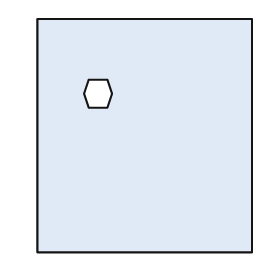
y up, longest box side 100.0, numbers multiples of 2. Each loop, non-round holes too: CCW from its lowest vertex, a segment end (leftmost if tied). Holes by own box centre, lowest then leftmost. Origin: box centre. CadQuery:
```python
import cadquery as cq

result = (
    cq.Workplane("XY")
    .moveTo(-46.0, -50.0)
    .lineTo(46.0, -50.0)
    .lineTo(46.0, 50.0)
    .lineTo(-46.0, 50.0)
    .close()
    .moveTo(-24.0, 12.0)
    .lineTo(-16.0, 12.0)
    .lineTo(-14.0, 18.0)
    .lineTo(-16.0, 24.0)
    .lineTo(-24.0, 24.0)
    .lineTo(-26.0, 18.0)
    .close()
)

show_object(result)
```